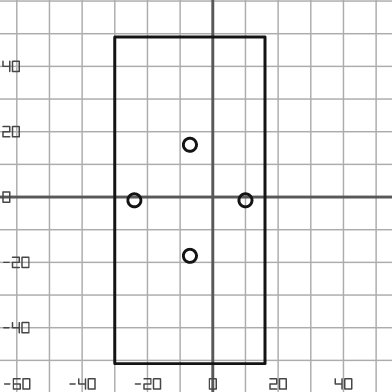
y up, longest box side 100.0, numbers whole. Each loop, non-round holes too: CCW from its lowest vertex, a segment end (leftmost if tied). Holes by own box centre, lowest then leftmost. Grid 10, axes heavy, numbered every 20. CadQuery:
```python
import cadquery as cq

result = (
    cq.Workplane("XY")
    .moveTo(-30.0, -51.0)
    .lineTo(16.0, -51.0)
    .lineTo(16.0, 49.0)
    .lineTo(-30.0, 49.0)
    .close()
    .moveTo(-7.0, -18.0)
    .circle(2.0)
    .moveTo(-24.0, -1.0)
    .circle(2.0)
    .moveTo(10.0, -1.0)
    .circle(2.0)
    .moveTo(-7.0, 16.0)
    .circle(2.0)
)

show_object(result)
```